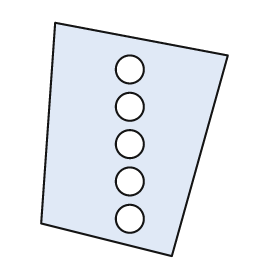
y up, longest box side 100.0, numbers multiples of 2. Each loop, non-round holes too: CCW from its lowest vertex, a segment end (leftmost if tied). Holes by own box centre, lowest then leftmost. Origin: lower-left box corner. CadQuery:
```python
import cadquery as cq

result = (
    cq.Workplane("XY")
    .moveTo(56.0, 0.0)
    .lineTo(80.0, 86.0)
    .lineTo(6.0, 100.0)
    .lineTo(0.0, 14.0)
    .close()
    .moveTo(38.0, 16.0)
    .circle(6.0)
    .moveTo(38.0, 32.0)
    .circle(6.0)
    .moveTo(38.0, 48.0)
    .circle(6.0)
    .moveTo(38.0, 64.0)
    .circle(6.0)
    .moveTo(38.0, 80.0)
    .circle(6.0)
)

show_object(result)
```